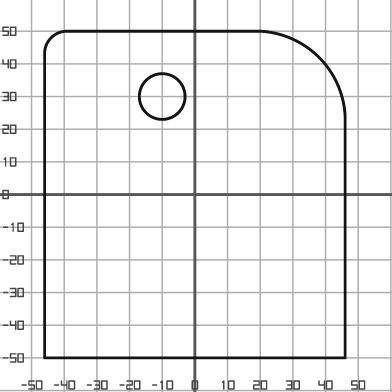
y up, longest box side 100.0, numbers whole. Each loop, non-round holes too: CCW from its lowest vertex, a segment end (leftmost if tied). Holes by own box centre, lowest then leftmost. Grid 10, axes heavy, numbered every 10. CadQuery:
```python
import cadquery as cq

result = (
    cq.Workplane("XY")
    .moveTo(-46.0, -50.0)
    .lineTo(46.0, -50.0)
    .lineTo(46.0, 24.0)
    .threePointArc((38.0, 42.0), (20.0, 50.0))
    .lineTo(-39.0, 50.0)
    .threePointArc((-44.0, 48.0), (-46.0, 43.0))
    .close()
    .moveTo(-10.0, 30.0)
    .circle(7.0)
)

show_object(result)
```